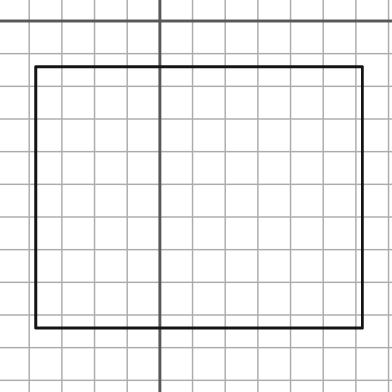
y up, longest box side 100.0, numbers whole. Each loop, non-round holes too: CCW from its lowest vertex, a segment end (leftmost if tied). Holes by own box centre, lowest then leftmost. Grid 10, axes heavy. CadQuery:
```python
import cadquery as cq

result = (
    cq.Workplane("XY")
    .moveTo(-38.0, -94.0)
    .lineTo(62.0, -94.0)
    .lineTo(62.0, -14.0)
    .lineTo(-38.0, -14.0)
    .close()
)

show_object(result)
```